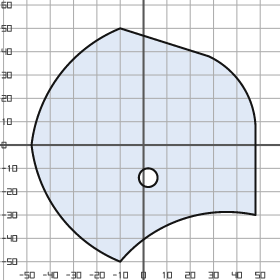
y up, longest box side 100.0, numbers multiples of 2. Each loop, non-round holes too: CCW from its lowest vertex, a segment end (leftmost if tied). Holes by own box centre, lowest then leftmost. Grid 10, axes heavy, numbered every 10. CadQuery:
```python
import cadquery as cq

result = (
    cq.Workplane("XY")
    .moveTo(-10.0, -50.0)
    .threePointArc((16.0, -32.0), (48.0, -30.0))
    .lineTo(48.0, 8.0)
    .threePointArc((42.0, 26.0), (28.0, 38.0))
    .lineTo(-10.0, 50.0)
    .threePointArc((-36.0, 30.0), (-48.0, 0.0))
    .threePointArc((-36.0, -30.0), (-10.0, -50.0))
    .close()
    .moveTo(2.0, -14.0)
    .circle(4.0)
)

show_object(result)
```